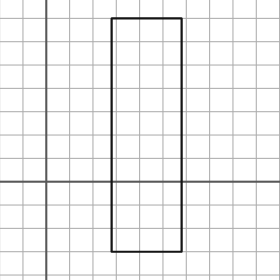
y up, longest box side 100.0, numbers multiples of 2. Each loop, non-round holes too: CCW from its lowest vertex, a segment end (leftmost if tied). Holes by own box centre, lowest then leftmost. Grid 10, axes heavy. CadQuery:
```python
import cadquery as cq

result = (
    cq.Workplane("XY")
    .moveTo(28.0, -30.0)
    .lineTo(58.0, -30.0)
    .lineTo(58.0, 70.0)
    .lineTo(28.0, 70.0)
    .close()
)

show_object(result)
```